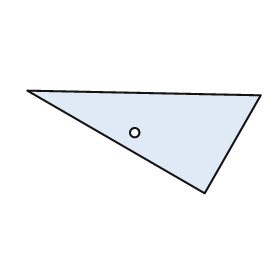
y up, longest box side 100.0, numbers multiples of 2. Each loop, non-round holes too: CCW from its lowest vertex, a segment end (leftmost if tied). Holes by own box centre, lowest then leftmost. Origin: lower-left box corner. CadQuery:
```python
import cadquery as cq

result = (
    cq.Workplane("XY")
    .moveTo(76.0, 0.0)
    .lineTo(100.0, 42.0)
    .lineTo(0.0, 44.0)
    .close()
    .moveTo(46.0, 26.0)
    .circle(2.0)
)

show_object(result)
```